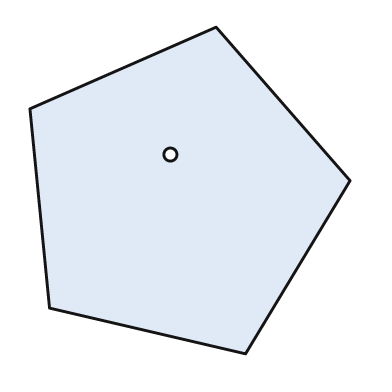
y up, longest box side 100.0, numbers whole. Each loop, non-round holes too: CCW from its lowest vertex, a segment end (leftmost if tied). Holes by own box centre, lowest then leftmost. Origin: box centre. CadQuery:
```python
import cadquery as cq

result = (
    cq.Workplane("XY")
    .moveTo(17.0, -50.0)
    .lineTo(49.0, 3.0)
    .lineTo(8.0, 50.0)
    .lineTo(-49.0, 25.0)
    .lineTo(-43.0, -36.0)
    .close()
    .moveTo(-6.0, 11.0)
    .circle(2.0)
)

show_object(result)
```